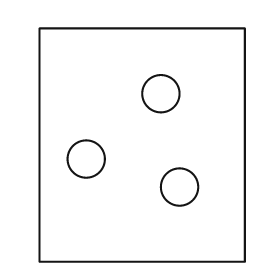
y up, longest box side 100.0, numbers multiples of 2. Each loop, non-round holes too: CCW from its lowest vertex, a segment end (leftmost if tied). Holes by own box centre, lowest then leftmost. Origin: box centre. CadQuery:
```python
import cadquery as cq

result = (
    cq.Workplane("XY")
    .moveTo(-44.0, -50.0)
    .lineTo(44.0, -50.0)
    .lineTo(44.0, 50.0)
    .lineTo(-44.0, 50.0)
    .close()
    .moveTo(16.0, -18.0)
    .circle(8.0)
    .moveTo(-24.0, -6.0)
    .circle(8.0)
    .moveTo(8.0, 22.0)
    .circle(8.0)
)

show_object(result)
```